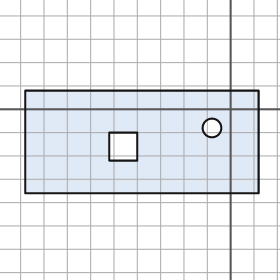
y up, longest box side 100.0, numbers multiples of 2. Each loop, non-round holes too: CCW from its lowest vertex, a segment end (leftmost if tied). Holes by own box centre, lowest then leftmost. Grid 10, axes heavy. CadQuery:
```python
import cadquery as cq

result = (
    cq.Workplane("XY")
    .moveTo(-88.0, -36.0)
    .lineTo(12.0, -36.0)
    .lineTo(12.0, 8.0)
    .lineTo(-88.0, 8.0)
    .close()
    .moveTo(-52.0, -22.0)
    .lineTo(-40.0, -22.0)
    .lineTo(-40.0, -10.0)
    .lineTo(-52.0, -10.0)
    .close()
    .moveTo(-8.0, -8.0)
    .circle(4.0)
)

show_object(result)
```